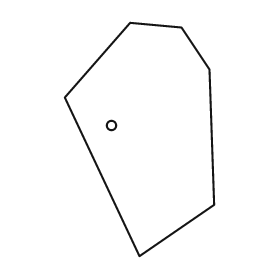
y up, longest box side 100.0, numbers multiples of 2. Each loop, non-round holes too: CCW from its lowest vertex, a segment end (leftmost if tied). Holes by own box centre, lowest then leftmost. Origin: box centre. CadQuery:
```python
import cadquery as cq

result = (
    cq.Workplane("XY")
    .moveTo(0.0, -50.0)
    .lineTo(32.0, -28.0)
    .lineTo(30.0, 30.0)
    .lineTo(18.0, 48.0)
    .lineTo(-4.0, 50.0)
    .lineTo(-32.0, 18.0)
    .close()
    .moveTo(-12.0, 6.0)
    .circle(2.0)
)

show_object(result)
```